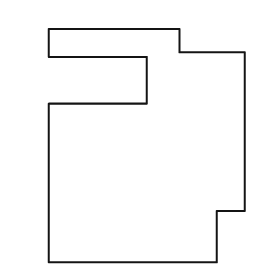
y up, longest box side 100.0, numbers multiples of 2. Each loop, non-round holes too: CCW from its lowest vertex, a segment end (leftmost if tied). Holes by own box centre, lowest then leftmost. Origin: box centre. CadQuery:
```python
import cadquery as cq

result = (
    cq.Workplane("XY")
    .moveTo(-42.0, -50.0)
    .lineTo(30.0, -50.0)
    .lineTo(30.0, -28.0)
    .lineTo(42.0, -28.0)
    .lineTo(42.0, 40.0)
    .lineTo(14.0, 40.0)
    .lineTo(14.0, 50.0)
    .lineTo(-42.0, 50.0)
    .lineTo(-42.0, 38.0)
    .lineTo(0.0, 38.0)
    .lineTo(0.0, 18.0)
    .lineTo(-42.0, 18.0)
    .close()
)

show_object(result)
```